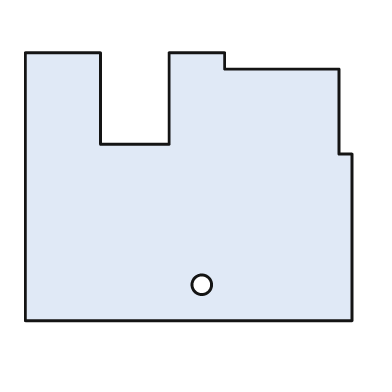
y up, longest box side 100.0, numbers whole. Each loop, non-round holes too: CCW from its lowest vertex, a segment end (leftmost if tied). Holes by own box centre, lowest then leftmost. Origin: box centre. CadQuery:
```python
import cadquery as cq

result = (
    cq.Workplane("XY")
    .moveTo(-50.0, -41.0)
    .lineTo(50.0, -41.0)
    .lineTo(50.0, 10.0)
    .lineTo(46.0, 10.0)
    .lineTo(46.0, 36.0)
    .lineTo(11.0, 36.0)
    .lineTo(11.0, 41.0)
    .lineTo(-6.0, 41.0)
    .lineTo(-6.0, 13.0)
    .lineTo(-27.0, 13.0)
    .lineTo(-27.0, 41.0)
    .lineTo(-50.0, 41.0)
    .close()
    .moveTo(4.0, -30.0)
    .circle(3.0)
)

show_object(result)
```